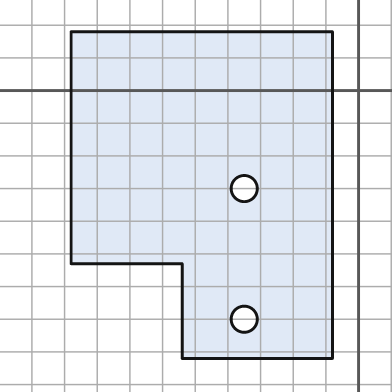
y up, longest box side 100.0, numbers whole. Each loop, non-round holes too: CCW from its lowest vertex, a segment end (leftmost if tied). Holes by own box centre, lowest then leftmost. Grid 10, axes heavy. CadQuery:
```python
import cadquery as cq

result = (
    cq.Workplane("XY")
    .moveTo(-54.0, -82.0)
    .lineTo(-8.0, -82.0)
    .lineTo(-8.0, 18.0)
    .lineTo(-88.0, 18.0)
    .lineTo(-88.0, -53.0)
    .lineTo(-54.0, -53.0)
    .close()
    .moveTo(-35.0, -70.0)
    .circle(4.0)
    .moveTo(-35.0, -30.0)
    .circle(4.0)
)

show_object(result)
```